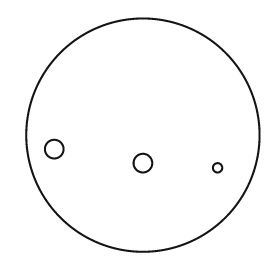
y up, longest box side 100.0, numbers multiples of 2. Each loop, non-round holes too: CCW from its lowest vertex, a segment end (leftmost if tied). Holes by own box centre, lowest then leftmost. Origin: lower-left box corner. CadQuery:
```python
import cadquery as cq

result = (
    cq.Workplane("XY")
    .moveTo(50.0, 50.0)
    .circle(50.0)
    .moveTo(82.0, 36.0)
    .circle(2.0)
    .moveTo(50.0, 38.0)
    .circle(4.0)
    .moveTo(12.0, 44.0)
    .circle(4.0)
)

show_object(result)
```